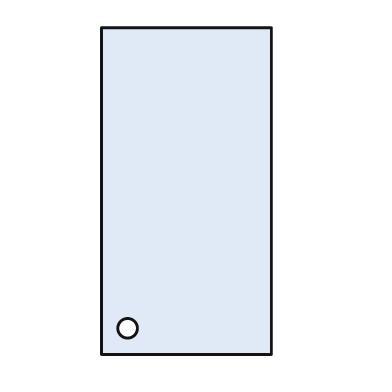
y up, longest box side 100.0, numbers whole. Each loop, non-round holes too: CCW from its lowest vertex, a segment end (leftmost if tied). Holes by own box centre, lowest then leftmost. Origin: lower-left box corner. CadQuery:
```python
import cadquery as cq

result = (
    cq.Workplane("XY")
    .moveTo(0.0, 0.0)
    .lineTo(52.0, 0.0)
    .lineTo(52.0, 100.0)
    .lineTo(0.0, 100.0)
    .close()
    .moveTo(8.0, 8.0)
    .circle(3.0)
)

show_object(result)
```